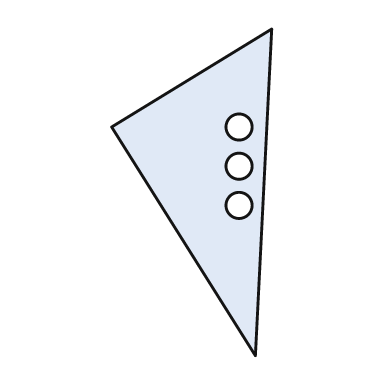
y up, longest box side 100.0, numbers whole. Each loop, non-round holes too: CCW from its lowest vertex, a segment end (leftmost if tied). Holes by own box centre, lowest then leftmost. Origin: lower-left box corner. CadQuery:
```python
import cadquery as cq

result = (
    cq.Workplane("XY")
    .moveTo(44.0, 0.0)
    .lineTo(49.0, 100.0)
    .lineTo(0.0, 70.0)
    .close()
    .moveTo(39.0, 46.0)
    .circle(4.0)
    .moveTo(39.0, 58.0)
    .circle(4.0)
    .moveTo(39.0, 70.0)
    .circle(4.0)
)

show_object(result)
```